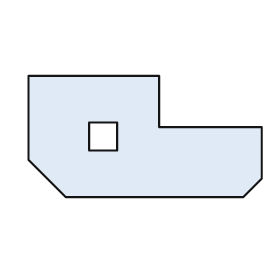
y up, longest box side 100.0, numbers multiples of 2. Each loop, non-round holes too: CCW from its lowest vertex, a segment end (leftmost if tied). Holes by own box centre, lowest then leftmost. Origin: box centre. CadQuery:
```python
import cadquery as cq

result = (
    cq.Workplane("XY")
    .moveTo(-34.0, -26.0)
    .lineTo(42.0, -26.0)
    .lineTo(50.0, -18.0)
    .lineTo(50.0, 4.0)
    .lineTo(6.0, 4.0)
    .lineTo(6.0, 26.0)
    .lineTo(-50.0, 26.0)
    .lineTo(-50.0, -10.0)
    .close()
    .moveTo(-24.0, -6.0)
    .lineTo(-12.0, -6.0)
    .lineTo(-12.0, 6.0)
    .lineTo(-24.0, 6.0)
    .close()
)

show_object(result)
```